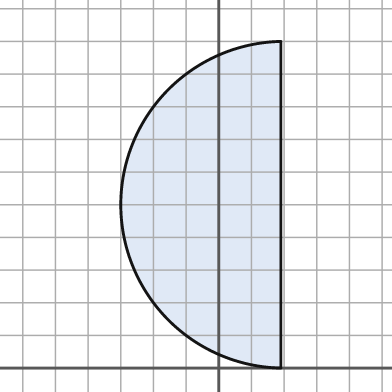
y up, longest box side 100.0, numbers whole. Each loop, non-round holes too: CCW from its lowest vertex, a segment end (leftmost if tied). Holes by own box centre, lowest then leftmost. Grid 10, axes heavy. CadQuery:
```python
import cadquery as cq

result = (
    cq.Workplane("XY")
    .moveTo(19.0, 0.0)
    .lineTo(19.0, 100.0)
    .threePointArc((-30.0, 50.0), (19.0, 0.0))
    .close()
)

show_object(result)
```